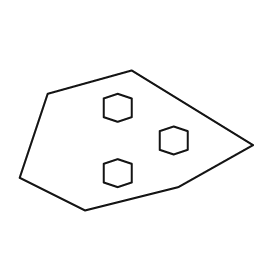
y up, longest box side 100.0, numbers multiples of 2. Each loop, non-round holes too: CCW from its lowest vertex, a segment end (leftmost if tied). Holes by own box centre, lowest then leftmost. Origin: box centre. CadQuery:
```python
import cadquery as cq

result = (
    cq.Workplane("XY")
    .moveTo(-22.0, -30.0)
    .lineTo(18.0, -20.0)
    .lineTo(50.0, -2.0)
    .lineTo(-2.0, 30.0)
    .lineTo(-38.0, 20.0)
    .lineTo(-50.0, -16.0)
    .close()
    .moveTo(-8.0, -20.0)
    .lineTo(-2.0, -18.0)
    .lineTo(-2.0, -10.0)
    .lineTo(-8.0, -8.0)
    .lineTo(-14.0, -10.0)
    .lineTo(-14.0, -18.0)
    .close()
    .moveTo(16.0, -6.0)
    .lineTo(22.0, -4.0)
    .lineTo(22.0, 4.0)
    .lineTo(16.0, 6.0)
    .lineTo(10.0, 4.0)
    .lineTo(10.0, -4.0)
    .close()
    .moveTo(-8.0, 8.0)
    .lineTo(-2.0, 10.0)
    .lineTo(-2.0, 18.0)
    .lineTo(-8.0, 20.0)
    .lineTo(-14.0, 18.0)
    .lineTo(-14.0, 10.0)
    .close()
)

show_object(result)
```